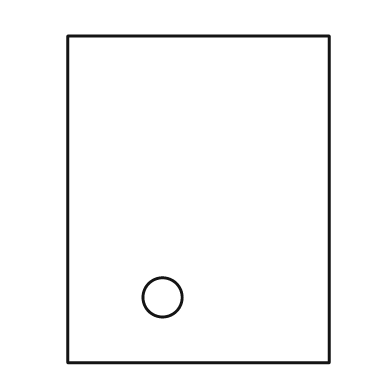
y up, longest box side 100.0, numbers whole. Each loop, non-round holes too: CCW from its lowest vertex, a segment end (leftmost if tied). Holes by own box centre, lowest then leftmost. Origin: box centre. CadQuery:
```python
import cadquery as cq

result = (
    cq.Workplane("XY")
    .moveTo(-40.0, -50.0)
    .lineTo(40.0, -50.0)
    .lineTo(40.0, 50.0)
    .lineTo(-40.0, 50.0)
    .close()
    .moveTo(-11.0, -30.0)
    .circle(6.0)
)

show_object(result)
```